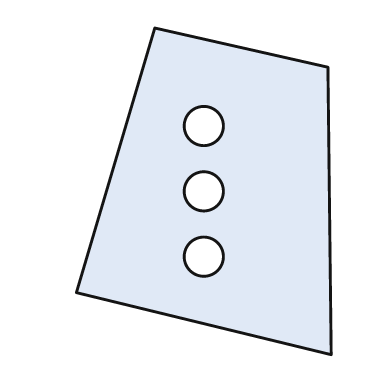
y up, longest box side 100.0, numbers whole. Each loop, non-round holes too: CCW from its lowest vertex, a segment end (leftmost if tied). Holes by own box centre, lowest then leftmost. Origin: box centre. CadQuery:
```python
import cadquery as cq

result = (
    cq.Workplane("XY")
    .moveTo(39.0, -50.0)
    .lineTo(38.0, 38.0)
    .lineTo(-15.0, 50.0)
    .lineTo(-39.0, -31.0)
    .close()
    .moveTo(0.0, -20.0)
    .circle(6.0)
    .moveTo(0.0, 0.0)
    .circle(6.0)
    .moveTo(0.0, 20.0)
    .circle(6.0)
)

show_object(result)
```